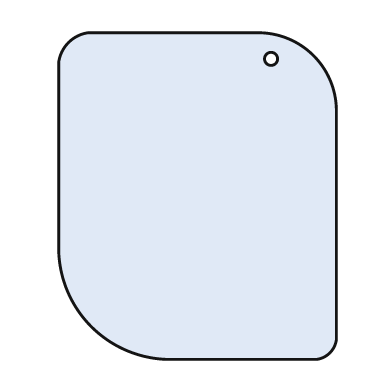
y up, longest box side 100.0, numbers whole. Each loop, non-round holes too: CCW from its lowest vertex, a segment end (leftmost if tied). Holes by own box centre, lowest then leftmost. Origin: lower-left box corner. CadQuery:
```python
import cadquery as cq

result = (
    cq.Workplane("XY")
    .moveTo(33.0, 0.0)
    .lineTo(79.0, 0.0)
    .threePointArc((83.0, 2.0), (85.0, 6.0))
    .lineTo(85.0, 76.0)
    .threePointArc((78.0, 93.0), (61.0, 100.0))
    .lineTo(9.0, 100.0)
    .threePointArc((3.0, 97.0), (0.0, 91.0))
    .lineTo(0.0, 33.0)
    .threePointArc((10.0, 10.0), (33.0, 0.0))
    .close()
    .moveTo(65.0, 92.0)
    .circle(2.0)
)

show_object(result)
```